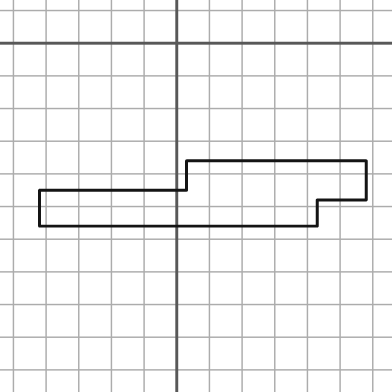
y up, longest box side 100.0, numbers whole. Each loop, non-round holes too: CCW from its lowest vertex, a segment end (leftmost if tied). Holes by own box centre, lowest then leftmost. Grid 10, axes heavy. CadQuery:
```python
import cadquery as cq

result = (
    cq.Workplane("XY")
    .moveTo(-42.0, -56.0)
    .lineTo(43.0, -56.0)
    .lineTo(43.0, -48.0)
    .lineTo(58.0, -48.0)
    .lineTo(58.0, -36.0)
    .lineTo(3.0, -36.0)
    .lineTo(3.0, -45.0)
    .lineTo(-42.0, -45.0)
    .close()
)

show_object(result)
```